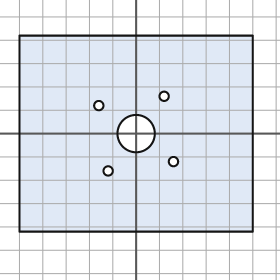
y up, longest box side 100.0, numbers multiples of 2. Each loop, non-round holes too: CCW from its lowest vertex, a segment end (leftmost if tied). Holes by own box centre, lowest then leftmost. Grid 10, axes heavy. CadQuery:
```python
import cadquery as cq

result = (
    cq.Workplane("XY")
    .moveTo(-50.0, -42.0)
    .lineTo(50.0, -42.0)
    .lineTo(50.0, 42.0)
    .lineTo(-50.0, 42.0)
    .close()
    .moveTo(-12.0, -16.0)
    .circle(2.0)
    .moveTo(16.0, -12.0)
    .circle(2.0)
    .moveTo(0.0, 0.0)
    .circle(8.0)
    .moveTo(-16.0, 12.0)
    .circle(2.0)
    .moveTo(12.0, 16.0)
    .circle(2.0)
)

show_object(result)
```